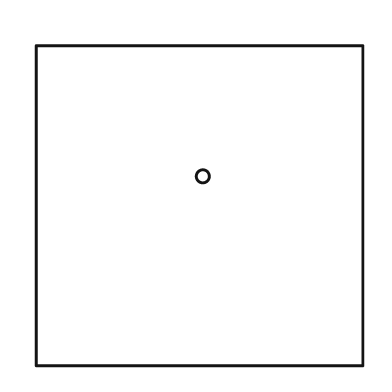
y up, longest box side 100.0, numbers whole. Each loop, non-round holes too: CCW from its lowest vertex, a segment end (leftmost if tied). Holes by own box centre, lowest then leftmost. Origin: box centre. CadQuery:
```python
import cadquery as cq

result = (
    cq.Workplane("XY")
    .moveTo(-50.0, -49.0)
    .lineTo(50.0, -49.0)
    .lineTo(50.0, 49.0)
    .lineTo(-50.0, 49.0)
    .close()
    .moveTo(1.0, 9.0)
    .circle(2.0)
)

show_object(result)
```